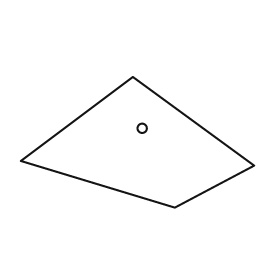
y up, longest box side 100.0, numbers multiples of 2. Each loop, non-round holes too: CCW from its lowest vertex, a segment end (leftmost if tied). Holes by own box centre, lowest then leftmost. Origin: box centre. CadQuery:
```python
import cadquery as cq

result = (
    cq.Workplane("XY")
    .moveTo(16.0, -28.0)
    .lineTo(50.0, -10.0)
    .lineTo(-2.0, 28.0)
    .lineTo(-50.0, -8.0)
    .close()
    .moveTo(2.0, 6.0)
    .circle(2.0)
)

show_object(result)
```